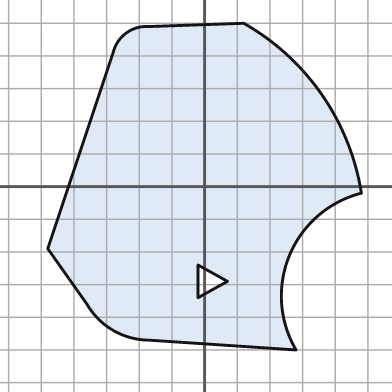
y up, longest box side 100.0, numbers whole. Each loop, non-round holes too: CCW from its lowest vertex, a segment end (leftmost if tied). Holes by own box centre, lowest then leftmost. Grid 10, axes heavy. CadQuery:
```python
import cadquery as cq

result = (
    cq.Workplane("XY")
    .moveTo(28.0, -50.0)
    .threePointArc((26.0, -21.0), (48.0, -2.0))
    .threePointArc((36.0, 28.0), (12.0, 50.0))
    .lineTo(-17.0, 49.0)
    .threePointArc((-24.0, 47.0), (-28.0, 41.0))
    .lineTo(-48.0, -19.0)
    .lineTo(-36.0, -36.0)
    .threePointArc((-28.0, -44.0), (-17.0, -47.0))
    .close()
    .moveTo(-2.0, -34.0)
    .lineTo(7.0, -29.0)
    .lineTo(-2.0, -24.0)
    .close()
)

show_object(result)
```